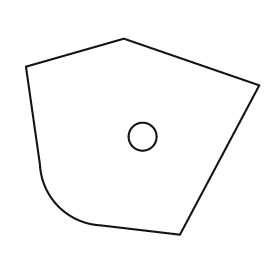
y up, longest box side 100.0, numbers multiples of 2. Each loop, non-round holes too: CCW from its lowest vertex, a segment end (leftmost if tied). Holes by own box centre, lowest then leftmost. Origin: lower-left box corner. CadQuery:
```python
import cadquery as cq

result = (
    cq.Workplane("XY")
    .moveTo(66.0, 0.0)
    .lineTo(100.0, 64.0)
    .lineTo(42.0, 84.0)
    .lineTo(0.0, 72.0)
    .lineTo(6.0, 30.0)
    .threePointArc((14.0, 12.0), (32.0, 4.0))
    .close()
    .moveTo(50.0, 42.0)
    .circle(6.0)
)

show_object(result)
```